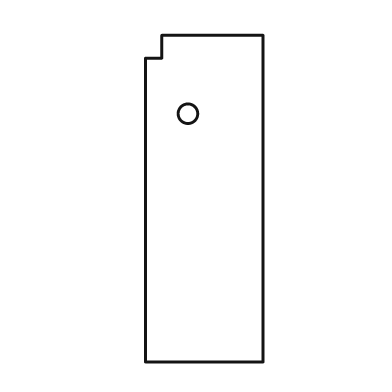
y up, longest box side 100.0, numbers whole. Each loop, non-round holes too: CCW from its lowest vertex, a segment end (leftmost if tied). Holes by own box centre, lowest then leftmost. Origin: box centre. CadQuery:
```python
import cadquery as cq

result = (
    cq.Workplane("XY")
    .moveTo(-18.0, -50.0)
    .lineTo(18.0, -50.0)
    .lineTo(18.0, 50.0)
    .lineTo(-13.0, 50.0)
    .lineTo(-13.0, 43.0)
    .lineTo(-18.0, 43.0)
    .close()
    .moveTo(-5.0, 26.0)
    .circle(3.0)
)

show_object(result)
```